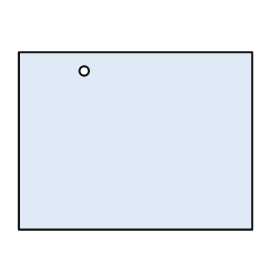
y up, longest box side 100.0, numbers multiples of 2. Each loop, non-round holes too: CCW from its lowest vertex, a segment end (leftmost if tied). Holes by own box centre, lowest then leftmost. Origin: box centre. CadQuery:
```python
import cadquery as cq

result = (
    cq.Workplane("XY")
    .moveTo(-50.0, -38.0)
    .lineTo(50.0, -38.0)
    .lineTo(50.0, 38.0)
    .lineTo(-50.0, 38.0)
    .close()
    .moveTo(-22.0, 30.0)
    .circle(2.0)
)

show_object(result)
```